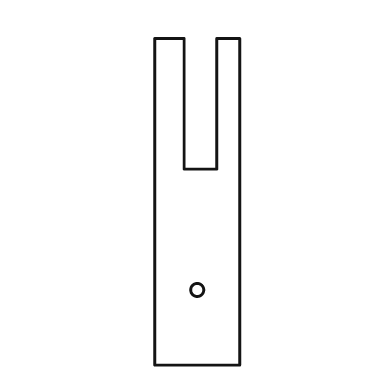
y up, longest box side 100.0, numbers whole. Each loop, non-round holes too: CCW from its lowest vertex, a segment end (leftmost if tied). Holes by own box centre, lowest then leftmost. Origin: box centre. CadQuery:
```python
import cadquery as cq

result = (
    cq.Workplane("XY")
    .moveTo(-13.0, -50.0)
    .lineTo(13.0, -50.0)
    .lineTo(13.0, 50.0)
    .lineTo(6.0, 50.0)
    .lineTo(6.0, 10.0)
    .lineTo(-4.0, 10.0)
    .lineTo(-4.0, 50.0)
    .lineTo(-13.0, 50.0)
    .close()
    .moveTo(0.0, -27.0)
    .circle(2.0)
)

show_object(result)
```